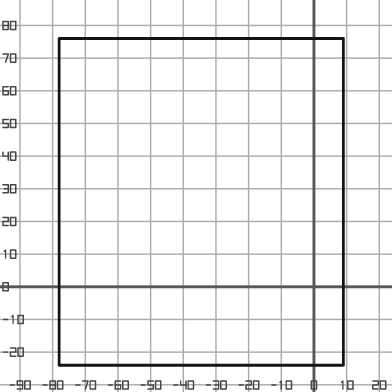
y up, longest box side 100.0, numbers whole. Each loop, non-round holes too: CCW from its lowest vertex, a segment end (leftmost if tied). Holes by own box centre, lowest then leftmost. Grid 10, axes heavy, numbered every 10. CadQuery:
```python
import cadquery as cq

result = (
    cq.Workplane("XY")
    .moveTo(-78.0, -24.0)
    .lineTo(9.0, -24.0)
    .lineTo(9.0, 76.0)
    .lineTo(-78.0, 76.0)
    .close()
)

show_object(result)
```